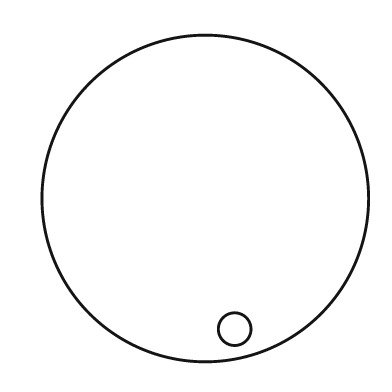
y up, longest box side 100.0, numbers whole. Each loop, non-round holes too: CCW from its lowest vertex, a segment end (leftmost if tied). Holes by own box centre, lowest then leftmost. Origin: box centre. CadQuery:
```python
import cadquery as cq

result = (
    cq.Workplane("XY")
    .moveTo(0.0, 0.0)
    .circle(50.0)
    .moveTo(9.0, -40.0)
    .circle(5.0)
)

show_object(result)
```